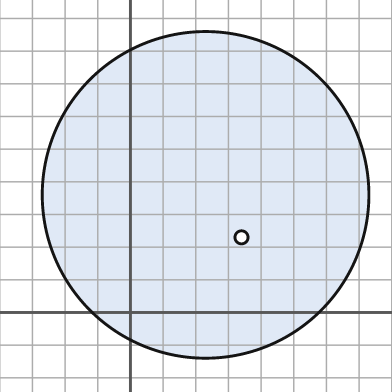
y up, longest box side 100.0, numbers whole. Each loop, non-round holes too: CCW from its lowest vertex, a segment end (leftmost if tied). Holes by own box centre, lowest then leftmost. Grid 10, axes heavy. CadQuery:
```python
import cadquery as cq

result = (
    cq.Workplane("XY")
    .moveTo(23.0, 36.0)
    .circle(50.0)
    .moveTo(34.0, 23.0)
    .circle(2.0)
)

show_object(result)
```